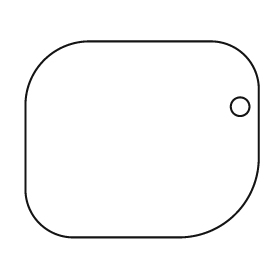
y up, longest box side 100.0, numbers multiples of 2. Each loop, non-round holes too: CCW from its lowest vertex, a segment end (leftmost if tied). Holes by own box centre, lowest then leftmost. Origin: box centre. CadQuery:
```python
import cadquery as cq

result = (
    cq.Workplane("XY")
    .moveTo(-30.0, -42.0)
    .lineTo(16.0, -42.0)
    .threePointArc((40.0, -32.0), (50.0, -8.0))
    .lineTo(50.0, 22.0)
    .threePointArc((44.0, 36.0), (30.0, 42.0))
    .lineTo(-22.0, 42.0)
    .threePointArc((-42.0, 34.0), (-50.0, 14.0))
    .lineTo(-50.0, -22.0)
    .threePointArc((-44.0, -36.0), (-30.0, -42.0))
    .close()
    .moveTo(42.0, 14.0)
    .circle(4.0)
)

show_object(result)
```